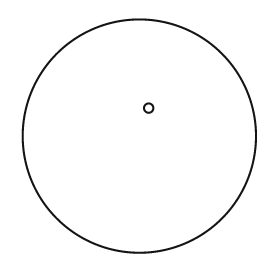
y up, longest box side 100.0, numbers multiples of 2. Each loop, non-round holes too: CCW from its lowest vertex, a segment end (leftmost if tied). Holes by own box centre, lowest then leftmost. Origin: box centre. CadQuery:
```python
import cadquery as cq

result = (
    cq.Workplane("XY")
    .moveTo(0.0, 0.0)
    .circle(50.0)
    .moveTo(4.0, 12.0)
    .circle(2.0)
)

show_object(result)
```